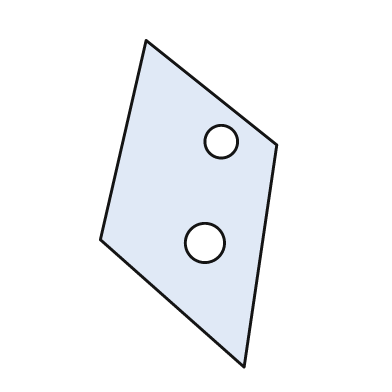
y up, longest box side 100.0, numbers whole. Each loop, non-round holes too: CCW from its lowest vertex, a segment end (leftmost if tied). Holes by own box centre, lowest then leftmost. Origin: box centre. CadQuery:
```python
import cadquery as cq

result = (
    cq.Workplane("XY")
    .moveTo(17.0, -50.0)
    .lineTo(27.0, 18.0)
    .lineTo(-13.0, 50.0)
    .lineTo(-27.0, -11.0)
    .close()
    .moveTo(5.0, -12.0)
    .circle(6.0)
    .moveTo(10.0, 19.0)
    .circle(5.0)
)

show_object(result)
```